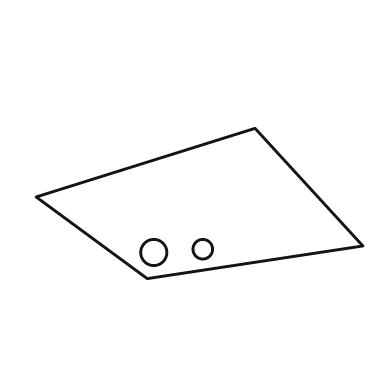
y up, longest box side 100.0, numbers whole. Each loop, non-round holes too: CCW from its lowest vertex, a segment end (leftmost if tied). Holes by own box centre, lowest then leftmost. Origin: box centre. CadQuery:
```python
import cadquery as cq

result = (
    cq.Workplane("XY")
    .moveTo(-16.0, -23.0)
    .lineTo(50.0, -13.0)
    .lineTo(17.0, 23.0)
    .lineTo(-50.0, 2.0)
    .close()
    .moveTo(-14.0, -15.0)
    .circle(4.0)
    .moveTo(1.0, -14.0)
    .circle(3.0)
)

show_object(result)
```